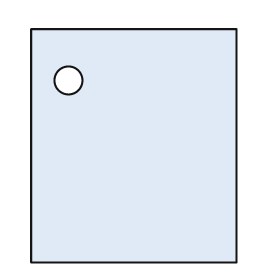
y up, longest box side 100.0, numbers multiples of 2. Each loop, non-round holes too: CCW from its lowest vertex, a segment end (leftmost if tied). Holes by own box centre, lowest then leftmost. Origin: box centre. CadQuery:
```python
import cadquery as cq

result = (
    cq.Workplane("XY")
    .moveTo(-44.0, -50.0)
    .lineTo(44.0, -50.0)
    .lineTo(44.0, 50.0)
    .lineTo(-44.0, 50.0)
    .close()
    .moveTo(-28.0, 28.0)
    .circle(6.0)
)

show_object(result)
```